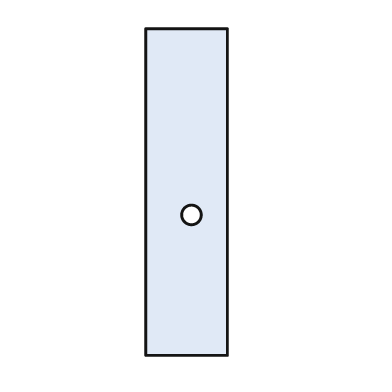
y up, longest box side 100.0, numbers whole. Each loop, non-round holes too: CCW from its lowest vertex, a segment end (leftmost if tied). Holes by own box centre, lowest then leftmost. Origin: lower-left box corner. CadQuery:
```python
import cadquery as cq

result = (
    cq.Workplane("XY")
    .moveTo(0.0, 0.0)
    .lineTo(25.0, 0.0)
    .lineTo(25.0, 100.0)
    .lineTo(0.0, 100.0)
    .close()
    .moveTo(14.0, 43.0)
    .circle(3.0)
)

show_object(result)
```